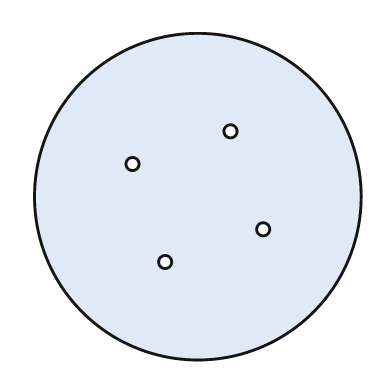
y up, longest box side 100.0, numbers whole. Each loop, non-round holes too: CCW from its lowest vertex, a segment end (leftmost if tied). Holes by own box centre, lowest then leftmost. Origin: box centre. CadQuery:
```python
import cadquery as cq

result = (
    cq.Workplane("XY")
    .moveTo(0.0, 0.0)
    .circle(50.0)
    .moveTo(-10.0, -20.0)
    .circle(2.0)
    .moveTo(20.0, -10.0)
    .circle(2.0)
    .moveTo(-20.0, 10.0)
    .circle(2.0)
    .moveTo(10.0, 20.0)
    .circle(2.0)
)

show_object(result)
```